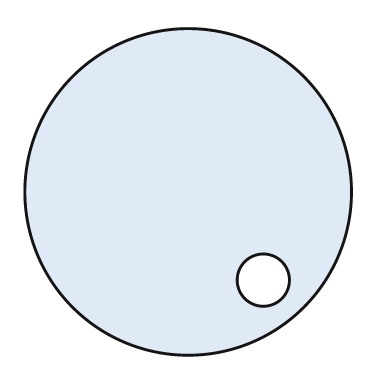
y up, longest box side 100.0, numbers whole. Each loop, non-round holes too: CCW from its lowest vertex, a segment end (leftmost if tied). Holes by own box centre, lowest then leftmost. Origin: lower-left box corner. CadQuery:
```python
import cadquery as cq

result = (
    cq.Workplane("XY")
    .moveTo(50.0, 50.0)
    .circle(50.0)
    .moveTo(73.0, 23.0)
    .circle(8.0)
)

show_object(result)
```